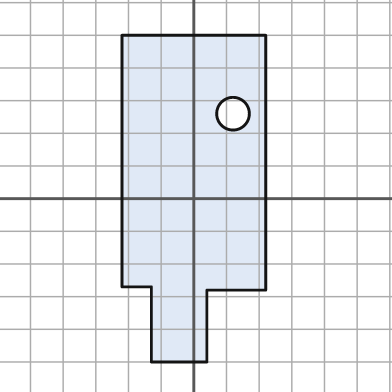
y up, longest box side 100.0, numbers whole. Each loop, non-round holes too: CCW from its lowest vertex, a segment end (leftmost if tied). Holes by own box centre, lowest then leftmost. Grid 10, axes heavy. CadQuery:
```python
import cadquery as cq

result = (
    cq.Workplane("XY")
    .moveTo(-13.0, -50.0)
    .lineTo(4.0, -50.0)
    .lineTo(4.0, -28.0)
    .lineTo(22.0, -28.0)
    .lineTo(22.0, 50.0)
    .lineTo(-22.0, 50.0)
    .lineTo(-22.0, -27.0)
    .lineTo(-13.0, -27.0)
    .close()
    .moveTo(12.0, 26.0)
    .circle(5.0)
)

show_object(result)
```